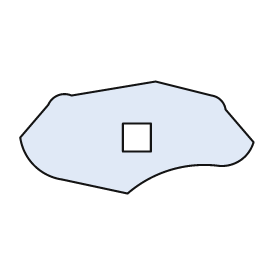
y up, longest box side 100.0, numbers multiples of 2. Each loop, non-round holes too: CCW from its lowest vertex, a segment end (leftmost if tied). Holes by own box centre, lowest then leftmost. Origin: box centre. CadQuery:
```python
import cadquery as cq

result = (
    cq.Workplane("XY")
    .moveTo(-4.0, -24.0)
    .threePointArc((14.0, -14.0), (34.0, -12.0))
    .threePointArc((44.0, -10.0), (50.0, -2.0))
    .lineTo(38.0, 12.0)
    .threePointArc((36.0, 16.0), (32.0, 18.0))
    .lineTo(8.0, 24.0)
    .lineTo(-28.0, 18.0)
    .threePointArc((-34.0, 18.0), (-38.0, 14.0))
    .lineTo(-50.0, 0.0)
    .threePointArc((-44.0, -12.0), (-32.0, -18.0))
    .close()
    .moveTo(-6.0, -6.0)
    .lineTo(6.0, -6.0)
    .lineTo(6.0, 6.0)
    .lineTo(-6.0, 6.0)
    .close()
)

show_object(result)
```